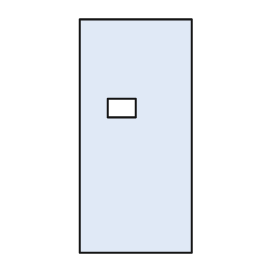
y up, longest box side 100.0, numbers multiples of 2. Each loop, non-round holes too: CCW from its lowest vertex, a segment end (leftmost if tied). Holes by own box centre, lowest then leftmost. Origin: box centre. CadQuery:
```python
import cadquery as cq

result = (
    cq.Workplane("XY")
    .moveTo(-24.0, -50.0)
    .lineTo(24.0, -50.0)
    .lineTo(24.0, 50.0)
    .lineTo(-24.0, 50.0)
    .close()
    .moveTo(-12.0, 8.0)
    .lineTo(0.0, 8.0)
    .lineTo(0.0, 16.0)
    .lineTo(-12.0, 16.0)
    .close()
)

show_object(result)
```